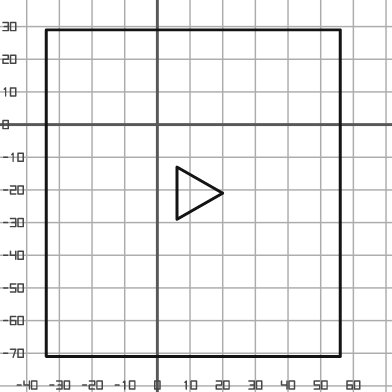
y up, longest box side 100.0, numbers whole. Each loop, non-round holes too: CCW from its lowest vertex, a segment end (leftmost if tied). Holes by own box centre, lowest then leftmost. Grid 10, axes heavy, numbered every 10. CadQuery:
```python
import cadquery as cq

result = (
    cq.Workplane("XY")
    .moveTo(-34.0, -71.0)
    .lineTo(56.0, -71.0)
    .lineTo(56.0, 29.0)
    .lineTo(-34.0, 29.0)
    .close()
    .moveTo(6.0, -29.0)
    .lineTo(20.0, -21.0)
    .lineTo(6.0, -13.0)
    .close()
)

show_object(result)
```